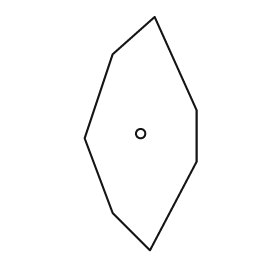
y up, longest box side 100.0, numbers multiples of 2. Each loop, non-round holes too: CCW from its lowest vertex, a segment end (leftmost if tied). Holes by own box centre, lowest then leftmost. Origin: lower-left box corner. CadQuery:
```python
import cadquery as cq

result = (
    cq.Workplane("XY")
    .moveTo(28.0, 0.0)
    .lineTo(48.0, 38.0)
    .lineTo(48.0, 60.0)
    .lineTo(30.0, 100.0)
    .lineTo(12.0, 84.0)
    .lineTo(0.0, 48.0)
    .lineTo(12.0, 16.0)
    .close()
    .moveTo(24.0, 50.0)
    .circle(2.0)
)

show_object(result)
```